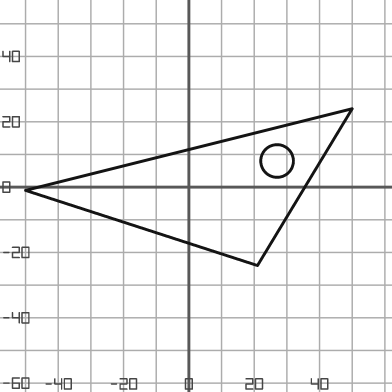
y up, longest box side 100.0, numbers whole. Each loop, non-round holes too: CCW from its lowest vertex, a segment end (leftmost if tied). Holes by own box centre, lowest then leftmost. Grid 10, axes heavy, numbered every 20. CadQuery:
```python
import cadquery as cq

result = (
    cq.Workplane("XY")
    .moveTo(21.0, -24.0)
    .lineTo(50.0, 24.0)
    .lineTo(-50.0, -1.0)
    .close()
    .moveTo(27.0, 8.0)
    .circle(5.0)
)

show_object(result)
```